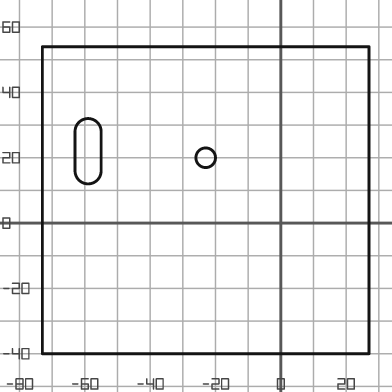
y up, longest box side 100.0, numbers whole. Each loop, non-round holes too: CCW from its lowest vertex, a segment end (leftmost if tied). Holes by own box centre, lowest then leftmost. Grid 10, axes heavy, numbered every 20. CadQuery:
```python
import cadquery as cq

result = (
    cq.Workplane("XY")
    .moveTo(-73.0, -40.0)
    .lineTo(27.0, -40.0)
    .lineTo(27.0, 54.0)
    .lineTo(-73.0, 54.0)
    .close()
    .moveTo(-23.0, 20.0)
    .circle(3.0)
    .moveTo(-63.0, 16.0)
    .threePointArc((-59.0, 12.0), (-55.0, 16.0))
    .lineTo(-55.0, 28.0)
    .threePointArc((-59.0, 32.0), (-63.0, 28.0))
    .close()
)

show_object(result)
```